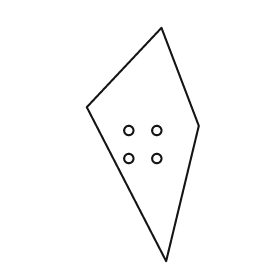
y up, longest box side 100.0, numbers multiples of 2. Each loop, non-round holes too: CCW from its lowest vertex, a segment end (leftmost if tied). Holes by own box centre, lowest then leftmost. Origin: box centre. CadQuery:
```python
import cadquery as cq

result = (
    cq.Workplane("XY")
    .moveTo(10.0, -50.0)
    .lineTo(24.0, 8.0)
    .lineTo(8.0, 50.0)
    .lineTo(-24.0, 16.0)
    .close()
    .moveTo(-6.0, -6.0)
    .circle(2.0)
    .moveTo(6.0, -6.0)
    .circle(2.0)
    .moveTo(-6.0, 6.0)
    .circle(2.0)
    .moveTo(6.0, 6.0)
    .circle(2.0)
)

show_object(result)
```